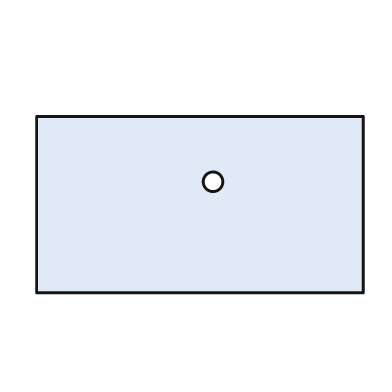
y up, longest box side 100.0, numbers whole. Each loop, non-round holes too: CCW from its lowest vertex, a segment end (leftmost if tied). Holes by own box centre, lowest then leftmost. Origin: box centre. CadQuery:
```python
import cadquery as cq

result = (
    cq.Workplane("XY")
    .moveTo(-50.0, -27.0)
    .lineTo(50.0, -27.0)
    .lineTo(50.0, 27.0)
    .lineTo(-50.0, 27.0)
    .close()
    .moveTo(4.0, 7.0)
    .circle(3.0)
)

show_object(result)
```